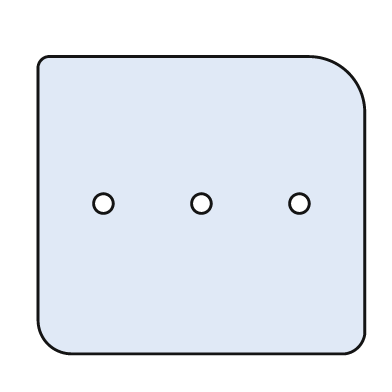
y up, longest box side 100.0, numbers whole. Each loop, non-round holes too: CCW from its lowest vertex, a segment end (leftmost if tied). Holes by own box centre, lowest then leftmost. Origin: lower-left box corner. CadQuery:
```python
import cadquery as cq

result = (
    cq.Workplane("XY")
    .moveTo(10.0, 0.0)
    .lineTo(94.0, 0.0)
    .threePointArc((98.0, 2.0), (100.0, 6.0))
    .lineTo(100.0, 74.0)
    .threePointArc((95.0, 86.0), (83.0, 91.0))
    .lineTo(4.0, 91.0)
    .threePointArc((1.0, 90.0), (0.0, 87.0))
    .lineTo(0.0, 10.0)
    .threePointArc((3.0, 3.0), (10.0, 0.0))
    .close()
    .moveTo(20.0, 46.0)
    .circle(3.0)
    .moveTo(50.0, 46.0)
    .circle(3.0)
    .moveTo(80.0, 46.0)
    .circle(3.0)
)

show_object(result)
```